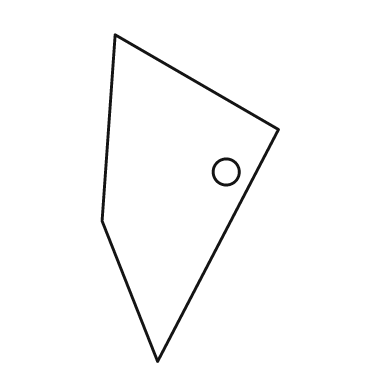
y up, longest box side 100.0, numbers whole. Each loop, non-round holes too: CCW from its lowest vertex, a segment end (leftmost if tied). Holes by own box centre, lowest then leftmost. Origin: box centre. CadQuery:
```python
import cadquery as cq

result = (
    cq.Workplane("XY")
    .moveTo(-10.0, -50.0)
    .lineTo(27.0, 21.0)
    .lineTo(-23.0, 50.0)
    .lineTo(-27.0, -7.0)
    .close()
    .moveTo(11.0, 8.0)
    .circle(4.0)
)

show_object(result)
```